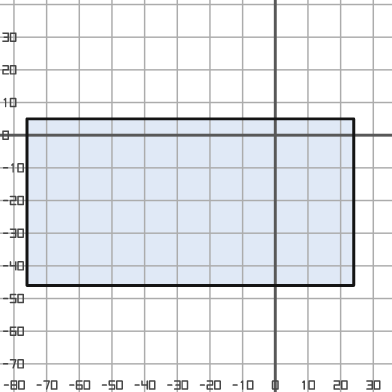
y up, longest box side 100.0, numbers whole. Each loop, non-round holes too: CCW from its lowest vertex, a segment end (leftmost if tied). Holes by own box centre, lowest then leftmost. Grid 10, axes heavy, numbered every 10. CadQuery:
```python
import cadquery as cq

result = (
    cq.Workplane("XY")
    .moveTo(-76.0, -46.0)
    .lineTo(24.0, -46.0)
    .lineTo(24.0, 5.0)
    .lineTo(-76.0, 5.0)
    .close()
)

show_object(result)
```